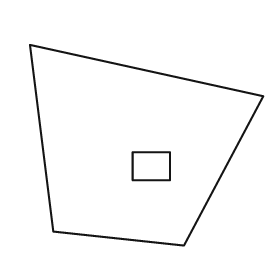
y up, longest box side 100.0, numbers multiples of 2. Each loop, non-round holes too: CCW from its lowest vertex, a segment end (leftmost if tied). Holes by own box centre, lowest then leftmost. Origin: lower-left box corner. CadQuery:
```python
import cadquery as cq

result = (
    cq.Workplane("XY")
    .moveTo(66.0, 0.0)
    .lineTo(100.0, 64.0)
    .lineTo(0.0, 86.0)
    .lineTo(10.0, 6.0)
    .close()
    .moveTo(44.0, 28.0)
    .lineTo(60.0, 28.0)
    .lineTo(60.0, 40.0)
    .lineTo(44.0, 40.0)
    .close()
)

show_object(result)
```